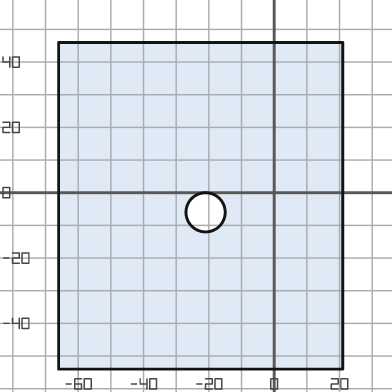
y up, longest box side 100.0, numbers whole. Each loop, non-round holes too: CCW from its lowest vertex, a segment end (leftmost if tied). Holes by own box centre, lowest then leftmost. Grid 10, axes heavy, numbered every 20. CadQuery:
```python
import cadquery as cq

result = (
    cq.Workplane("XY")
    .moveTo(-66.0, -54.0)
    .lineTo(21.0, -54.0)
    .lineTo(21.0, 46.0)
    .lineTo(-66.0, 46.0)
    .close()
    .moveTo(-21.0, -6.0)
    .circle(6.0)
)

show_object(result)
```